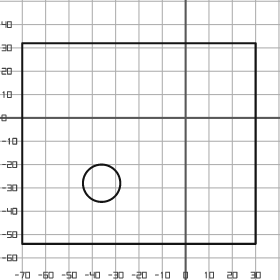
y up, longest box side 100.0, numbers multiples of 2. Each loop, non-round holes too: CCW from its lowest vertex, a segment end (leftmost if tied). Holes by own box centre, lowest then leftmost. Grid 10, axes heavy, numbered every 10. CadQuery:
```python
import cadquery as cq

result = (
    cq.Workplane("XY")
    .moveTo(-70.0, -54.0)
    .lineTo(30.0, -54.0)
    .lineTo(30.0, 32.0)
    .lineTo(-70.0, 32.0)
    .close()
    .moveTo(-36.0, -28.0)
    .circle(8.0)
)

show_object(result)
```